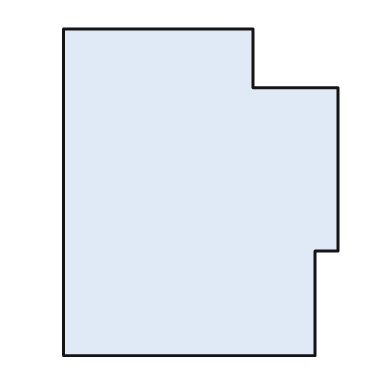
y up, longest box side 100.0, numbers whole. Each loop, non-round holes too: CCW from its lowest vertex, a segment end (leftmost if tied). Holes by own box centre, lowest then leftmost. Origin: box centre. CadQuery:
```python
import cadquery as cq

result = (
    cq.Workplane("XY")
    .moveTo(-42.0, -50.0)
    .lineTo(35.0, -50.0)
    .lineTo(35.0, -18.0)
    .lineTo(42.0, -18.0)
    .lineTo(42.0, 32.0)
    .lineTo(16.0, 32.0)
    .lineTo(16.0, 50.0)
    .lineTo(-42.0, 50.0)
    .close()
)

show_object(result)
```